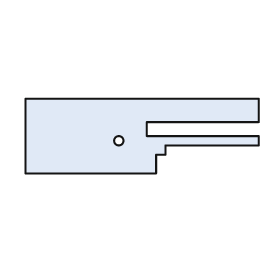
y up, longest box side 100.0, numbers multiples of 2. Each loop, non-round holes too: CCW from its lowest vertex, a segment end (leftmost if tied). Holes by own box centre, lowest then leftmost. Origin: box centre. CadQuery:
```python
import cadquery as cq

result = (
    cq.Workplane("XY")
    .moveTo(-50.0, -16.0)
    .lineTo(6.0, -16.0)
    .lineTo(6.0, -8.0)
    .lineTo(10.0, -8.0)
    .lineTo(10.0, -4.0)
    .lineTo(50.0, -4.0)
    .lineTo(50.0, 0.0)
    .lineTo(2.0, 0.0)
    .lineTo(2.0, 6.0)
    .lineTo(50.0, 6.0)
    .lineTo(50.0, 16.0)
    .lineTo(-50.0, 16.0)
    .close()
    .moveTo(-10.0, -2.0)
    .circle(2.0)
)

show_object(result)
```